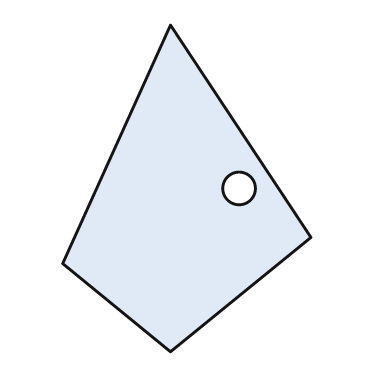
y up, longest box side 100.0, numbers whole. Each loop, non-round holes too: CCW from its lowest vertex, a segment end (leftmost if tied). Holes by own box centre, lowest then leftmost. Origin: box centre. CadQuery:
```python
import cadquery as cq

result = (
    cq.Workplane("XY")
    .moveTo(-5.0, -50.0)
    .lineTo(38.0, -15.0)
    .lineTo(-5.0, 50.0)
    .lineTo(-38.0, -23.0)
    .close()
    .moveTo(16.0, 0.0)
    .circle(5.0)
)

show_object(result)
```